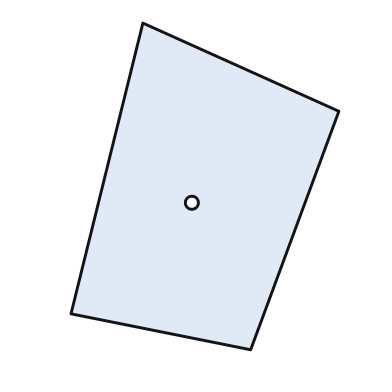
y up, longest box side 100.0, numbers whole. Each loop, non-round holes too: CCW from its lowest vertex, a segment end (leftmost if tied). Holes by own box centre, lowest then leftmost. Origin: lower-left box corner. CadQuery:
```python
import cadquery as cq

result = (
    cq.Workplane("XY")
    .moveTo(55.0, 0.0)
    .lineTo(82.0, 73.0)
    .lineTo(22.0, 100.0)
    .lineTo(0.0, 11.0)
    .close()
    .moveTo(37.0, 45.0)
    .circle(2.0)
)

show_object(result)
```